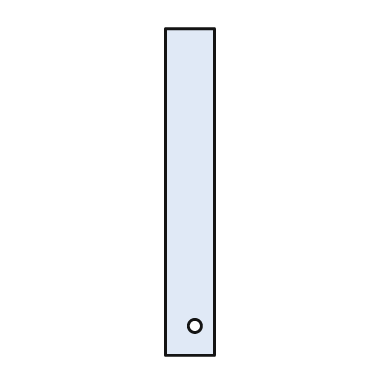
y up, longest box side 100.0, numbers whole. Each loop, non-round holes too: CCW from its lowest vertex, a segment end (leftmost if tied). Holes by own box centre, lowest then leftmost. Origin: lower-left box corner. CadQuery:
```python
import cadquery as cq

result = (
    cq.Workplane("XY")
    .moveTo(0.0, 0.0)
    .lineTo(15.0, 0.0)
    .lineTo(15.0, 100.0)
    .lineTo(0.0, 100.0)
    .close()
    .moveTo(9.0, 9.0)
    .circle(2.0)
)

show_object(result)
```